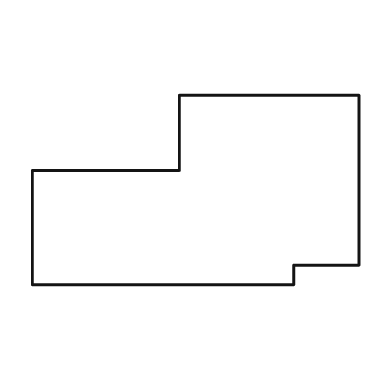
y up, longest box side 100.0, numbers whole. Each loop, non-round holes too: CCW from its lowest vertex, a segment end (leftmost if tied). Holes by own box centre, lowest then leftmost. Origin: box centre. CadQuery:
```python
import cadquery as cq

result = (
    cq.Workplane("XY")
    .moveTo(-50.0, -29.0)
    .lineTo(30.0, -29.0)
    .lineTo(30.0, -23.0)
    .lineTo(50.0, -23.0)
    .lineTo(50.0, 29.0)
    .lineTo(-5.0, 29.0)
    .lineTo(-5.0, 6.0)
    .lineTo(-50.0, 6.0)
    .close()
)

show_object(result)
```